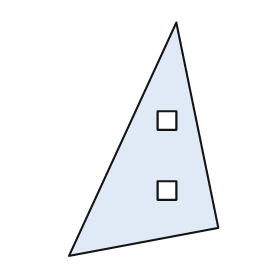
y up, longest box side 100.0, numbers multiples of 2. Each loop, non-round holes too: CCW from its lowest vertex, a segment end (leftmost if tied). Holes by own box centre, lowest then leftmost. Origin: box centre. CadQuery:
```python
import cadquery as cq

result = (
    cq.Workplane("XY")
    .moveTo(-32.0, -50.0)
    .lineTo(32.0, -38.0)
    .lineTo(14.0, 50.0)
    .close()
    .moveTo(6.0, -26.0)
    .lineTo(14.0, -26.0)
    .lineTo(14.0, -18.0)
    .lineTo(6.0, -18.0)
    .close()
    .moveTo(6.0, 4.0)
    .lineTo(14.0, 4.0)
    .lineTo(14.0, 12.0)
    .lineTo(6.0, 12.0)
    .close()
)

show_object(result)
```